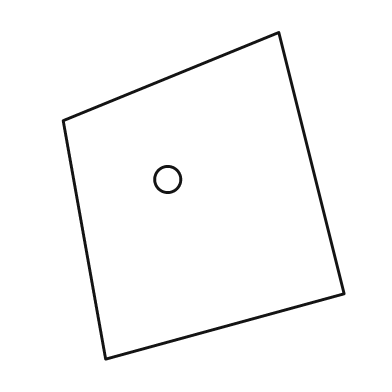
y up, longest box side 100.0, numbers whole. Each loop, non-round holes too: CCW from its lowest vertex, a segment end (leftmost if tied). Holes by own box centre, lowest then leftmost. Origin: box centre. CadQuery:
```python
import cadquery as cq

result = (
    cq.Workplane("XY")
    .moveTo(-30.0, -50.0)
    .lineTo(43.0, -30.0)
    .lineTo(23.0, 50.0)
    .lineTo(-43.0, 23.0)
    .close()
    .moveTo(-11.0, 5.0)
    .circle(4.0)
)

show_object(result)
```